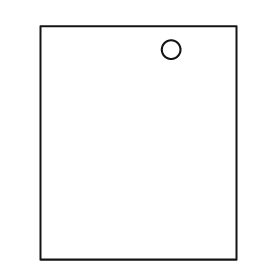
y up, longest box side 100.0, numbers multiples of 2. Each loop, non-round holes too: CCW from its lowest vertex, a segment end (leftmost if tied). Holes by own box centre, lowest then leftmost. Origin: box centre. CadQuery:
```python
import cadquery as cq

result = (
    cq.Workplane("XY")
    .moveTo(-42.0, -50.0)
    .lineTo(42.0, -50.0)
    .lineTo(42.0, 50.0)
    .lineTo(-42.0, 50.0)
    .close()
    .moveTo(14.0, 40.0)
    .circle(4.0)
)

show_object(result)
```